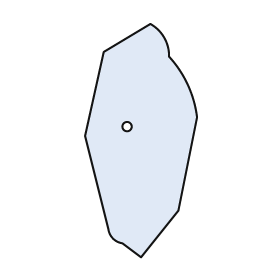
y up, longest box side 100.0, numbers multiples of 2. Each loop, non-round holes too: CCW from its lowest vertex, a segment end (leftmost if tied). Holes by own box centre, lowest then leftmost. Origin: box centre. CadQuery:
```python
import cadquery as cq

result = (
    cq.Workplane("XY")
    .moveTo(0.0, -50.0)
    .lineTo(16.0, -30.0)
    .lineTo(24.0, 10.0)
    .threePointArc((20.0, 24.0), (12.0, 36.0))
    .threePointArc((10.0, 44.0), (4.0, 50.0))
    .lineTo(-16.0, 38.0)
    .lineTo(-24.0, 2.0)
    .lineTo(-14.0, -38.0)
    .threePointArc((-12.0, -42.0), (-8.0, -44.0))
    .close()
    .moveTo(-6.0, 6.0)
    .circle(2.0)
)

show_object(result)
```